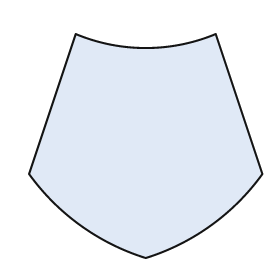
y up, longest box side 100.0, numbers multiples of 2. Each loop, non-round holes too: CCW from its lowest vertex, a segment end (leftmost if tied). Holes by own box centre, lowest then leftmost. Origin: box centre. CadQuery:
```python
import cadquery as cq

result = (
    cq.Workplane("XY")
    .moveTo(0.0, -48.0)
    .threePointArc((28.0, -34.0), (50.0, -12.0))
    .lineTo(30.0, 48.0)
    .threePointArc((0.0, 42.0), (-30.0, 48.0))
    .lineTo(-50.0, -12.0)
    .threePointArc((-28.0, -34.0), (0.0, -48.0))
    .close()
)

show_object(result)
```